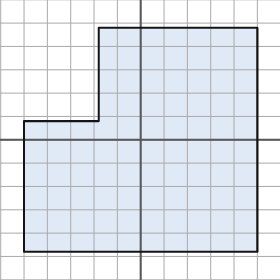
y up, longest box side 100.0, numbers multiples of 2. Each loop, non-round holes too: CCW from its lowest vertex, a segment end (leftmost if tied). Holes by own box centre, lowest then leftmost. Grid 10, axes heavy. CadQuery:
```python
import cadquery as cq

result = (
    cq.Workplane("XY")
    .moveTo(-50.0, -48.0)
    .lineTo(50.0, -48.0)
    .lineTo(50.0, 48.0)
    .lineTo(-18.0, 48.0)
    .lineTo(-18.0, 8.0)
    .lineTo(-50.0, 8.0)
    .close()
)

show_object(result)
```